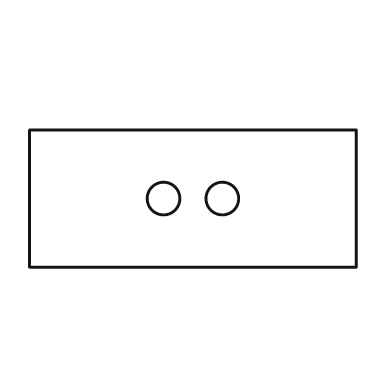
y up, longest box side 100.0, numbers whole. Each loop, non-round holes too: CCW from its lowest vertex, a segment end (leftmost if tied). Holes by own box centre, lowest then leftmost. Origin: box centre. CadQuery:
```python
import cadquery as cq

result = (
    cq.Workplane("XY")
    .moveTo(-50.0, -21.0)
    .lineTo(50.0, -21.0)
    .lineTo(50.0, 21.0)
    .lineTo(-50.0, 21.0)
    .close()
    .moveTo(-9.0, 0.0)
    .circle(5.0)
    .moveTo(9.0, 0.0)
    .circle(5.0)
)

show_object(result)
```